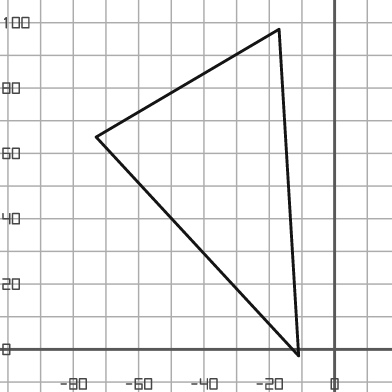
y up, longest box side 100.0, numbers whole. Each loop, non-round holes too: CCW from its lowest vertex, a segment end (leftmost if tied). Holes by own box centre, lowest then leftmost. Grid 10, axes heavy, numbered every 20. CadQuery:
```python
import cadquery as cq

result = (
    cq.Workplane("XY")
    .moveTo(-11.0, -2.0)
    .lineTo(-17.0, 98.0)
    .lineTo(-73.0, 65.0)
    .close()
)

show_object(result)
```